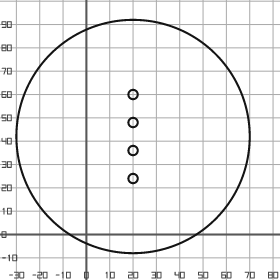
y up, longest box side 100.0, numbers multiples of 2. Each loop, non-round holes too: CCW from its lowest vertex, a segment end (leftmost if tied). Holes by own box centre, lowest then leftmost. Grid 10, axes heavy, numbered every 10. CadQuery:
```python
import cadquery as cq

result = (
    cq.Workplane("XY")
    .moveTo(20.0, 42.0)
    .circle(50.0)
    .moveTo(20.0, 24.0)
    .circle(2.0)
    .moveTo(20.0, 36.0)
    .circle(2.0)
    .moveTo(20.0, 48.0)
    .circle(2.0)
    .moveTo(20.0, 60.0)
    .circle(2.0)
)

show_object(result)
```